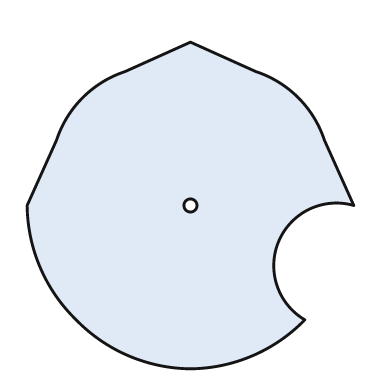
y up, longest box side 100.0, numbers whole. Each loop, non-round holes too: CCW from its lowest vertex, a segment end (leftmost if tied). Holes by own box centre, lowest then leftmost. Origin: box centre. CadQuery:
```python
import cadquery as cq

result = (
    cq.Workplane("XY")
    .moveTo(0.0, -50.0)
    .threePointArc((19.0, -46.0), (35.0, -35.0))
    .threePointArc((27.0, -11.0), (50.0, 0.0))
    .lineTo(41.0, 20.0)
    .threePointArc((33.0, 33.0), (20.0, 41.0))
    .lineTo(0.0, 50.0)
    .lineTo(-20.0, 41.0)
    .threePointArc((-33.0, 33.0), (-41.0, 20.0))
    .lineTo(-50.0, 0.0)
    .threePointArc((-46.0, -19.0), (-35.0, -35.0))
    .threePointArc((-19.0, -46.0), (0.0, -50.0))
    .close()
    .moveTo(0.0, 0.0)
    .circle(2.0)
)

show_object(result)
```